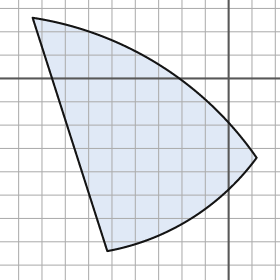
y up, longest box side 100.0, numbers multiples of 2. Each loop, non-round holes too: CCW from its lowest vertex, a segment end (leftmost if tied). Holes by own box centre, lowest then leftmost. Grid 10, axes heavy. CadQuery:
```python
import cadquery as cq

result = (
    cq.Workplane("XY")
    .moveTo(-52.0, -74.0)
    .threePointArc((-16.0, -60.0), (12.0, -34.0))
    .threePointArc((-30.0, 6.0), (-84.0, 26.0))
    .close()
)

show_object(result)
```